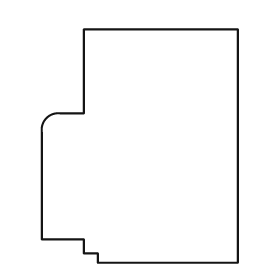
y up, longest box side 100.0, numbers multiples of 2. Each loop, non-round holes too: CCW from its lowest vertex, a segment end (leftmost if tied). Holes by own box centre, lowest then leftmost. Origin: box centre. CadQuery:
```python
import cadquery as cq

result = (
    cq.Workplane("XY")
    .moveTo(-18.0, -50.0)
    .lineTo(42.0, -50.0)
    .lineTo(42.0, 50.0)
    .lineTo(-24.0, 50.0)
    .lineTo(-24.0, 14.0)
    .lineTo(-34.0, 14.0)
    .threePointArc((-40.0, 12.0), (-42.0, 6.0))
    .lineTo(-42.0, -40.0)
    .lineTo(-24.0, -40.0)
    .lineTo(-24.0, -46.0)
    .lineTo(-18.0, -46.0)
    .close()
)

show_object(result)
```